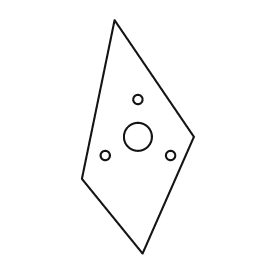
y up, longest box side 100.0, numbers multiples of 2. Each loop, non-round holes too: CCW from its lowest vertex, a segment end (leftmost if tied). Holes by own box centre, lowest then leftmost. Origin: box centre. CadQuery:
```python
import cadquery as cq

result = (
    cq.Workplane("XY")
    .moveTo(2.0, -50.0)
    .lineTo(24.0, 0.0)
    .lineTo(-10.0, 50.0)
    .lineTo(-24.0, -18.0)
    .close()
    .moveTo(-14.0, -8.0)
    .circle(2.0)
    .moveTo(14.0, -8.0)
    .circle(2.0)
    .moveTo(0.0, 0.0)
    .circle(6.0)
    .moveTo(0.0, 16.0)
    .circle(2.0)
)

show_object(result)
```